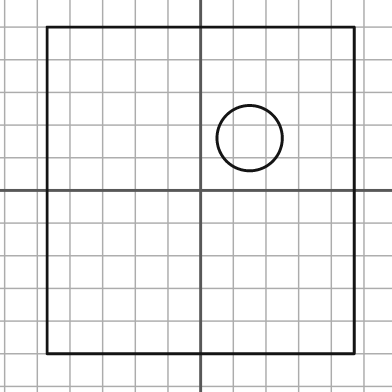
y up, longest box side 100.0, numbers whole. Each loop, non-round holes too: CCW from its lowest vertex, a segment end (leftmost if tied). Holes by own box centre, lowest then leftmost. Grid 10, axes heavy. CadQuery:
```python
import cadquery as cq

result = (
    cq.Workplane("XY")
    .moveTo(-47.0, -50.0)
    .lineTo(47.0, -50.0)
    .lineTo(47.0, 50.0)
    .lineTo(-47.0, 50.0)
    .close()
    .moveTo(15.0, 16.0)
    .circle(10.0)
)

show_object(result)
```